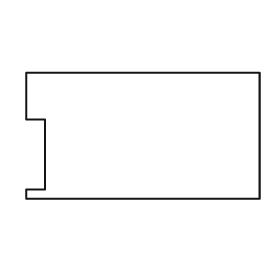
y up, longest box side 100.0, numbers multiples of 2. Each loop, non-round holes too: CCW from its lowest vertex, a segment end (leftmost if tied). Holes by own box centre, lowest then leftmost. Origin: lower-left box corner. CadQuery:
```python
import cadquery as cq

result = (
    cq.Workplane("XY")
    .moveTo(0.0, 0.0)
    .lineTo(100.0, 0.0)
    .lineTo(100.0, 54.0)
    .lineTo(0.0, 54.0)
    .lineTo(0.0, 34.0)
    .lineTo(8.0, 34.0)
    .lineTo(8.0, 4.0)
    .lineTo(0.0, 4.0)
    .close()
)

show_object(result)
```